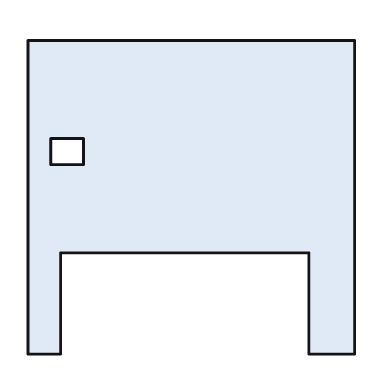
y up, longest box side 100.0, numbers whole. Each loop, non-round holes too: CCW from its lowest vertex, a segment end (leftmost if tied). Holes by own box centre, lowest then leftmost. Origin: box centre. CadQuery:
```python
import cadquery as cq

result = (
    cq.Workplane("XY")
    .moveTo(-50.0, -48.0)
    .lineTo(-40.0, -48.0)
    .lineTo(-40.0, -17.0)
    .lineTo(36.0, -17.0)
    .lineTo(36.0, -48.0)
    .lineTo(50.0, -48.0)
    .lineTo(50.0, 48.0)
    .lineTo(-50.0, 48.0)
    .close()
    .moveTo(-43.0, 10.0)
    .lineTo(-33.0, 10.0)
    .lineTo(-33.0, 18.0)
    .lineTo(-43.0, 18.0)
    .close()
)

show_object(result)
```